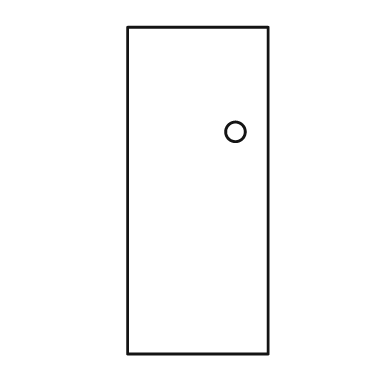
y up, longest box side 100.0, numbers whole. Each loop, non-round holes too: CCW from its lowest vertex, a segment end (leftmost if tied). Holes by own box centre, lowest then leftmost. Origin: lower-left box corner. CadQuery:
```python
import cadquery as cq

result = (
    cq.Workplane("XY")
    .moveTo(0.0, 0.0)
    .lineTo(43.0, 0.0)
    .lineTo(43.0, 100.0)
    .lineTo(0.0, 100.0)
    .close()
    .moveTo(33.0, 68.0)
    .circle(3.0)
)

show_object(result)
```